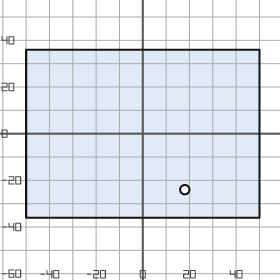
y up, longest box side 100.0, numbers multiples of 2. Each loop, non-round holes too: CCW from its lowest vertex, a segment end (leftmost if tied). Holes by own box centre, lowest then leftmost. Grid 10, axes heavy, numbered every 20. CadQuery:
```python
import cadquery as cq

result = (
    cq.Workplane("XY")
    .moveTo(-50.0, -36.0)
    .lineTo(50.0, -36.0)
    .lineTo(50.0, 36.0)
    .lineTo(-50.0, 36.0)
    .close()
    .moveTo(18.0, -24.0)
    .circle(2.0)
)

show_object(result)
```